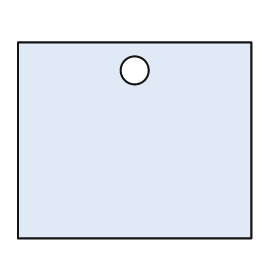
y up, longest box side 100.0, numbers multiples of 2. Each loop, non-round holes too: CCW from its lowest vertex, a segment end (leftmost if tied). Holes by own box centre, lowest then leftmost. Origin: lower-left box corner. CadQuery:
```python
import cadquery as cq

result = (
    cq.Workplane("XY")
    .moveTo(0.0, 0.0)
    .lineTo(100.0, 0.0)
    .lineTo(100.0, 84.0)
    .lineTo(0.0, 84.0)
    .close()
    .moveTo(50.0, 72.0)
    .circle(6.0)
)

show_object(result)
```